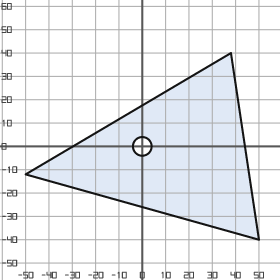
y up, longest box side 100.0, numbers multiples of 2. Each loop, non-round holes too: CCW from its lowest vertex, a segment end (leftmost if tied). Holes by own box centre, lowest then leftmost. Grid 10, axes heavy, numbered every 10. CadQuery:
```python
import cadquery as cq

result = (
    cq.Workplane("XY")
    .moveTo(50.0, -40.0)
    .lineTo(38.0, 40.0)
    .lineTo(-50.0, -12.0)
    .close()
    .moveTo(0.0, 0.0)
    .circle(4.0)
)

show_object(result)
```